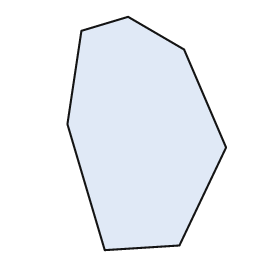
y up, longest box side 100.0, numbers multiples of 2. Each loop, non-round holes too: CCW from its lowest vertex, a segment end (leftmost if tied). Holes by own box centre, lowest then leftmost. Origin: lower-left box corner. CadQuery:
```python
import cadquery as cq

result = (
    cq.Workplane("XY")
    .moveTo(16.0, 0.0)
    .lineTo(48.0, 2.0)
    .lineTo(68.0, 44.0)
    .lineTo(50.0, 86.0)
    .lineTo(26.0, 100.0)
    .lineTo(6.0, 94.0)
    .lineTo(0.0, 54.0)
    .close()
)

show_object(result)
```